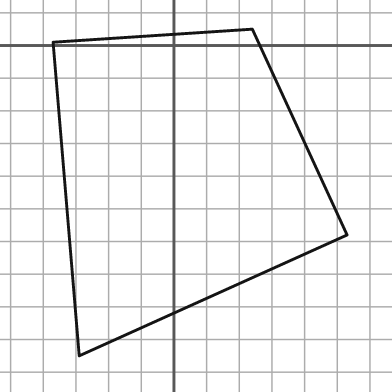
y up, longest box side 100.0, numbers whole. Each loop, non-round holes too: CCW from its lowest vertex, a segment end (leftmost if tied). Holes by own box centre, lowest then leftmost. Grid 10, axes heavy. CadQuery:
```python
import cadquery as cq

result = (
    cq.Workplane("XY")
    .moveTo(-29.0, -95.0)
    .lineTo(53.0, -58.0)
    .lineTo(24.0, 5.0)
    .lineTo(-37.0, 1.0)
    .close()
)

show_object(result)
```